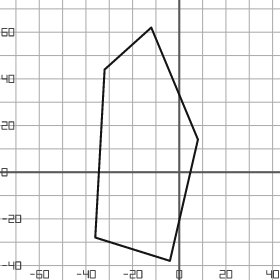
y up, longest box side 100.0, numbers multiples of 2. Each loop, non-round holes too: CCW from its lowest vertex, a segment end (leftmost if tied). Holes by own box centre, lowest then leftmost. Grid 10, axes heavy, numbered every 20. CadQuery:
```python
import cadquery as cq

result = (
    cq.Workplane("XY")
    .moveTo(-4.0, -38.0)
    .lineTo(8.0, 14.0)
    .lineTo(-12.0, 62.0)
    .lineTo(-32.0, 44.0)
    .lineTo(-36.0, -28.0)
    .close()
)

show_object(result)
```